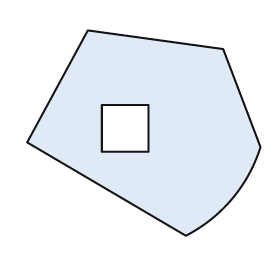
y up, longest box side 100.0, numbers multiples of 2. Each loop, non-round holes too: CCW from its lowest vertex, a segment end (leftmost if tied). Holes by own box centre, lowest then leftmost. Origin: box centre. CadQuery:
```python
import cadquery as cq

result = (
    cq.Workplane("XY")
    .moveTo(18.0, -44.0)
    .threePointArc((38.0, -28.0), (50.0, -6.0))
    .lineTo(34.0, 36.0)
    .lineTo(-24.0, 44.0)
    .lineTo(-50.0, -4.0)
    .close()
    .moveTo(-18.0, -8.0)
    .lineTo(2.0, -8.0)
    .lineTo(2.0, 12.0)
    .lineTo(-18.0, 12.0)
    .close()
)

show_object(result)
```